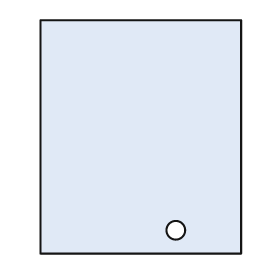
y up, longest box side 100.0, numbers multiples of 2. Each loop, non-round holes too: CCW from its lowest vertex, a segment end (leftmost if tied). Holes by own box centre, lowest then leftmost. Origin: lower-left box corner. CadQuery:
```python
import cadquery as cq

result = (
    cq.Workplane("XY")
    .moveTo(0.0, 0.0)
    .lineTo(86.0, 0.0)
    .lineTo(86.0, 100.0)
    .lineTo(0.0, 100.0)
    .close()
    .moveTo(58.0, 10.0)
    .circle(4.0)
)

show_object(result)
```